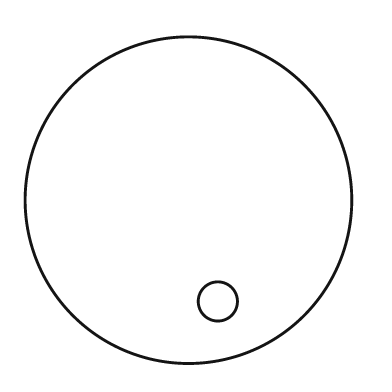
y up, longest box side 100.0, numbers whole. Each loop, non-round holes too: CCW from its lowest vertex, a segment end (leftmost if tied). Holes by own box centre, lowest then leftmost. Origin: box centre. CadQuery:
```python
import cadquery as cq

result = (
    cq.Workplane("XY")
    .moveTo(0.0, 0.0)
    .circle(50.0)
    .moveTo(9.0, -31.0)
    .circle(6.0)
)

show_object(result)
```